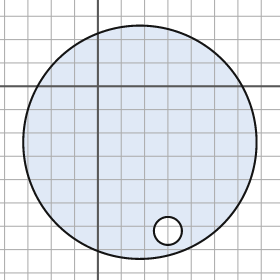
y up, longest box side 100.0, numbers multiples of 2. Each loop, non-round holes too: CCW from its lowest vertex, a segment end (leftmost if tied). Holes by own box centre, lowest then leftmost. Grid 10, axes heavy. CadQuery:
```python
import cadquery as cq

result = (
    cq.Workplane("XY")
    .moveTo(18.0, -24.0)
    .circle(50.0)
    .moveTo(30.0, -62.0)
    .circle(6.0)
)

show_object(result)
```